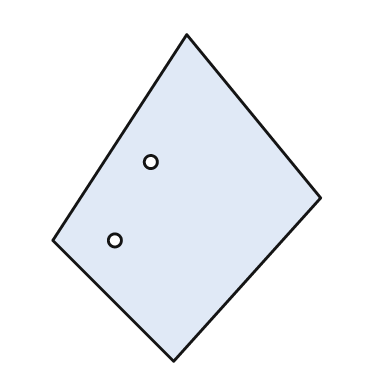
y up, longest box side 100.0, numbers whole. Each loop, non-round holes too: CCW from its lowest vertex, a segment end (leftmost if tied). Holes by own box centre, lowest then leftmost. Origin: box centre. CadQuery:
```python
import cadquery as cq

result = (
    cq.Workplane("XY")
    .moveTo(-4.0, -50.0)
    .lineTo(41.0, 0.0)
    .lineTo(0.0, 50.0)
    .lineTo(-41.0, -13.0)
    .close()
    .moveTo(-22.0, -13.0)
    .circle(2.0)
    .moveTo(-11.0, 11.0)
    .circle(2.0)
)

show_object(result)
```